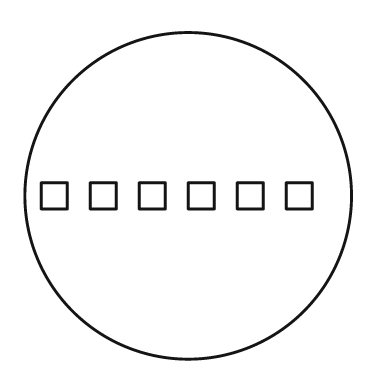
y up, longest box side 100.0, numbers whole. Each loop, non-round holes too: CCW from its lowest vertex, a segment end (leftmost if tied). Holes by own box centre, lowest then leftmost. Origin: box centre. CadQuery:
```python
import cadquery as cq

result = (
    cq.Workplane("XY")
    .moveTo(0.0, 0.0)
    .circle(50.0)
    .moveTo(-45.0, -4.0)
    .lineTo(-37.0, -4.0)
    .lineTo(-37.0, 4.0)
    .lineTo(-45.0, 4.0)
    .close()
    .moveTo(-30.0, -4.0)
    .lineTo(-22.0, -4.0)
    .lineTo(-22.0, 4.0)
    .lineTo(-30.0, 4.0)
    .close()
    .moveTo(-15.0, -4.0)
    .lineTo(-7.0, -4.0)
    .lineTo(-7.0, 4.0)
    .lineTo(-15.0, 4.0)
    .close()
    .moveTo(0.0, -4.0)
    .lineTo(8.0, -4.0)
    .lineTo(8.0, 4.0)
    .lineTo(0.0, 4.0)
    .close()
    .moveTo(15.0, -4.0)
    .lineTo(23.0, -4.0)
    .lineTo(23.0, 4.0)
    .lineTo(15.0, 4.0)
    .close()
    .moveTo(30.0, -4.0)
    .lineTo(38.0, -4.0)
    .lineTo(38.0, 4.0)
    .lineTo(30.0, 4.0)
    .close()
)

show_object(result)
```